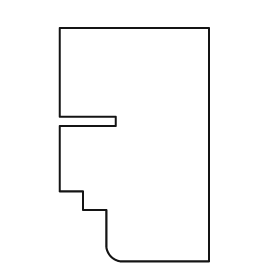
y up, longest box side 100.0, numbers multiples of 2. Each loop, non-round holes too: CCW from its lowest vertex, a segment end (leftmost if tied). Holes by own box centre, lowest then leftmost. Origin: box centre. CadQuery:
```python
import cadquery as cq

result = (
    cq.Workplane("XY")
    .moveTo(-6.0, -50.0)
    .lineTo(32.0, -50.0)
    .lineTo(32.0, 50.0)
    .lineTo(-32.0, 50.0)
    .lineTo(-32.0, 12.0)
    .lineTo(-8.0, 12.0)
    .lineTo(-8.0, 8.0)
    .lineTo(-32.0, 8.0)
    .lineTo(-32.0, -20.0)
    .lineTo(-22.0, -20.0)
    .lineTo(-22.0, -28.0)
    .lineTo(-12.0, -28.0)
    .lineTo(-12.0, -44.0)
    .threePointArc((-10.0, -48.0), (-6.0, -50.0))
    .close()
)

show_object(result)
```